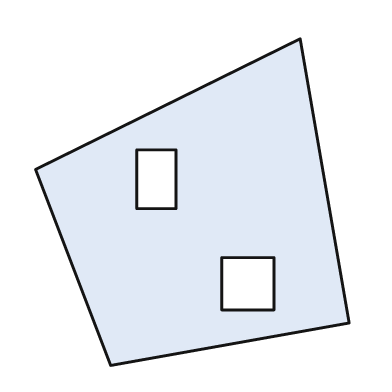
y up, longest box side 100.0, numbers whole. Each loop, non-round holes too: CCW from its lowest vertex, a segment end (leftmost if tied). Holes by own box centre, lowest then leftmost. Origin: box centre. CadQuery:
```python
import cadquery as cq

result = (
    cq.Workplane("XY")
    .moveTo(-25.0, -50.0)
    .lineTo(48.0, -37.0)
    .lineTo(33.0, 50.0)
    .lineTo(-48.0, 10.0)
    .close()
    .moveTo(9.0, -33.0)
    .lineTo(25.0, -33.0)
    .lineTo(25.0, -17.0)
    .lineTo(9.0, -17.0)
    .close()
    .moveTo(-17.0, -2.0)
    .lineTo(-5.0, -2.0)
    .lineTo(-5.0, 16.0)
    .lineTo(-17.0, 16.0)
    .close()
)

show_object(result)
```